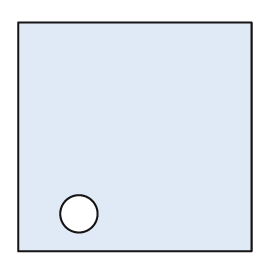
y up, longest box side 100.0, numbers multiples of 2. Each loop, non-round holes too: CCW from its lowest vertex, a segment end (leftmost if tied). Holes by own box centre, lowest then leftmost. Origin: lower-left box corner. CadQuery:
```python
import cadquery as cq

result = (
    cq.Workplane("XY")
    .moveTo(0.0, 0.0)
    .lineTo(100.0, 0.0)
    .lineTo(100.0, 98.0)
    .lineTo(0.0, 98.0)
    .close()
    .moveTo(26.0, 16.0)
    .circle(8.0)
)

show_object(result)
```